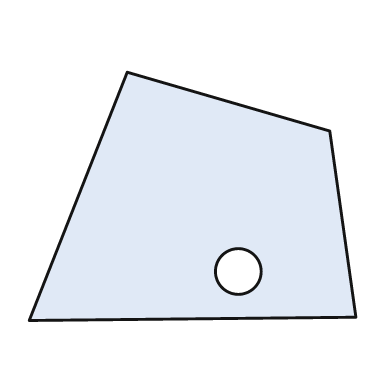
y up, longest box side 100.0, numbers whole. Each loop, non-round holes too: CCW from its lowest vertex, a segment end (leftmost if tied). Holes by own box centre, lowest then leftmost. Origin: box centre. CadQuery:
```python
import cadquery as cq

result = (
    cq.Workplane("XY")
    .moveTo(-50.0, -38.0)
    .lineTo(50.0, -37.0)
    .lineTo(42.0, 20.0)
    .lineTo(-20.0, 38.0)
    .close()
    .moveTo(14.0, -23.0)
    .circle(7.0)
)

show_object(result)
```